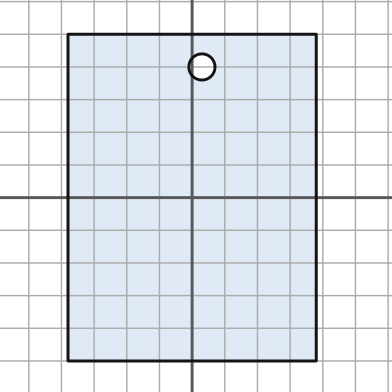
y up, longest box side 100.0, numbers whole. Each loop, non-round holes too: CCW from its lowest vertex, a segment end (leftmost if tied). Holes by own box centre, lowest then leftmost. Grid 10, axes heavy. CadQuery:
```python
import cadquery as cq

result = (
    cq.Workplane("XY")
    .moveTo(-38.0, -50.0)
    .lineTo(38.0, -50.0)
    .lineTo(38.0, 50.0)
    .lineTo(-38.0, 50.0)
    .close()
    .moveTo(3.0, 40.0)
    .circle(4.0)
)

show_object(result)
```